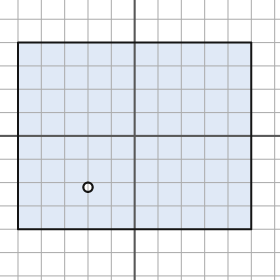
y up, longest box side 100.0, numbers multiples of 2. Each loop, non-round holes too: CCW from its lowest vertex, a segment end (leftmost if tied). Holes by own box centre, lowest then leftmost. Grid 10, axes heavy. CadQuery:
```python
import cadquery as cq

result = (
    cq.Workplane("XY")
    .moveTo(-50.0, -40.0)
    .lineTo(50.0, -40.0)
    .lineTo(50.0, 40.0)
    .lineTo(-50.0, 40.0)
    .close()
    .moveTo(-20.0, -22.0)
    .circle(2.0)
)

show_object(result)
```